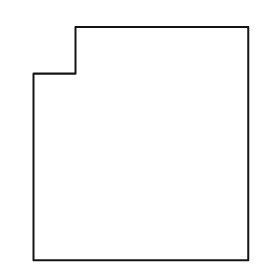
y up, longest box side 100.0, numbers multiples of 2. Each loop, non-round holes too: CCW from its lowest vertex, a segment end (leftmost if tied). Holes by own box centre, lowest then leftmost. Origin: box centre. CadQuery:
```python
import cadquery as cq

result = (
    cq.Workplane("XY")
    .moveTo(-46.0, -50.0)
    .lineTo(46.0, -50.0)
    .lineTo(46.0, 50.0)
    .lineTo(-28.0, 50.0)
    .lineTo(-28.0, 30.0)
    .lineTo(-46.0, 30.0)
    .close()
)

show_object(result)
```